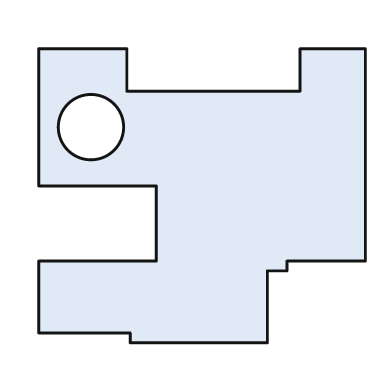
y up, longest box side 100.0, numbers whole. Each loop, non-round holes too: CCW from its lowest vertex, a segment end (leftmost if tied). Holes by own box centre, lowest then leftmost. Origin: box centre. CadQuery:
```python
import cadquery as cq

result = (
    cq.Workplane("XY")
    .moveTo(-22.0, -45.0)
    .lineTo(20.0, -45.0)
    .lineTo(20.0, -23.0)
    .lineTo(26.0, -23.0)
    .lineTo(26.0, -20.0)
    .lineTo(50.0, -20.0)
    .lineTo(50.0, 45.0)
    .lineTo(30.0, 45.0)
    .lineTo(30.0, 32.0)
    .lineTo(-23.0, 32.0)
    .lineTo(-23.0, 45.0)
    .lineTo(-50.0, 45.0)
    .lineTo(-50.0, 3.0)
    .lineTo(-14.0, 3.0)
    .lineTo(-14.0, -20.0)
    .lineTo(-50.0, -20.0)
    .lineTo(-50.0, -42.0)
    .lineTo(-22.0, -42.0)
    .close()
    .moveTo(-34.0, 21.0)
    .circle(10.0)
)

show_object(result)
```